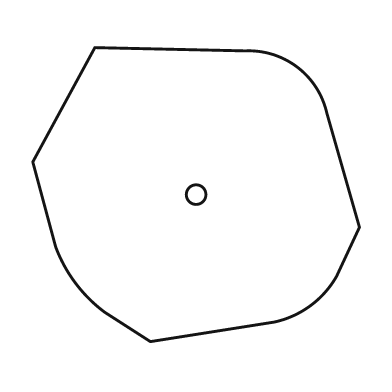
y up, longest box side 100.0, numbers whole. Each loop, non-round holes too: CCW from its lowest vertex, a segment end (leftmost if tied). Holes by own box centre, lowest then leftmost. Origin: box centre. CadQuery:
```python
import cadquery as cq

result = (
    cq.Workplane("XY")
    .moveTo(-14.0, -45.0)
    .lineTo(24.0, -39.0)
    .threePointArc((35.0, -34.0), (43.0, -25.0))
    .lineTo(50.0, -10.0)
    .lineTo(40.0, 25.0)
    .threePointArc((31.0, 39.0), (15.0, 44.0))
    .lineTo(-31.0, 45.0)
    .lineTo(-50.0, 10.0)
    .lineTo(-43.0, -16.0)
    .threePointArc((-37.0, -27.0), (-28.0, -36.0))
    .close()
    .moveTo(0.0, 0.0)
    .circle(3.0)
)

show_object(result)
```